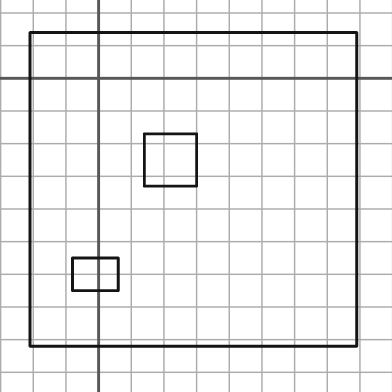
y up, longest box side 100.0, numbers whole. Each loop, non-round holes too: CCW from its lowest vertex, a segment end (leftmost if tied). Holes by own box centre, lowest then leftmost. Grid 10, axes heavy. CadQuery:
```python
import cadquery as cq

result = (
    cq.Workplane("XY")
    .moveTo(-21.0, -82.0)
    .lineTo(79.0, -82.0)
    .lineTo(79.0, 14.0)
    .lineTo(-21.0, 14.0)
    .close()
    .moveTo(-8.0, -65.0)
    .lineTo(6.0, -65.0)
    .lineTo(6.0, -55.0)
    .lineTo(-8.0, -55.0)
    .close()
    .moveTo(14.0, -33.0)
    .lineTo(30.0, -33.0)
    .lineTo(30.0, -17.0)
    .lineTo(14.0, -17.0)
    .close()
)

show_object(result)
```